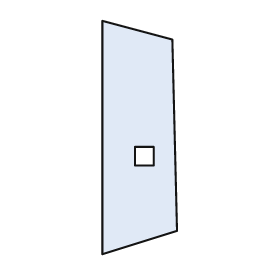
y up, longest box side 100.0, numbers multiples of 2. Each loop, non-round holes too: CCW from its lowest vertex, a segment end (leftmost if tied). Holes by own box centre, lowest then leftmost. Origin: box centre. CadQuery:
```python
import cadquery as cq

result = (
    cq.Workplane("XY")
    .moveTo(-16.0, -50.0)
    .lineTo(16.0, -40.0)
    .lineTo(14.0, 42.0)
    .lineTo(-16.0, 50.0)
    .close()
    .moveTo(-2.0, -12.0)
    .lineTo(6.0, -12.0)
    .lineTo(6.0, -4.0)
    .lineTo(-2.0, -4.0)
    .close()
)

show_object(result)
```